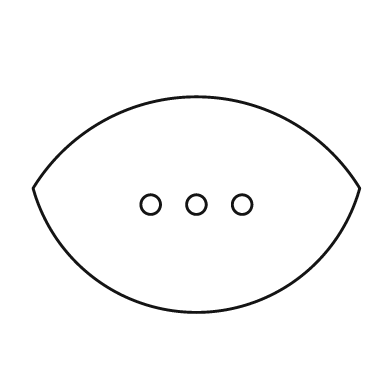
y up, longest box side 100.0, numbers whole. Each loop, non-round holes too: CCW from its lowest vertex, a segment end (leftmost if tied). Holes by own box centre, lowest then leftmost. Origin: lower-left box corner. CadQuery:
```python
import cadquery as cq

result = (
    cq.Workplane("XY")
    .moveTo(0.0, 38.0)
    .threePointArc((50.0, 0.0), (100.0, 38.0))
    .threePointArc((50.0, 66.0), (0.0, 38.0))
    .close()
    .moveTo(36.0, 33.0)
    .circle(3.0)
    .moveTo(50.0, 33.0)
    .circle(3.0)
    .moveTo(64.0, 33.0)
    .circle(3.0)
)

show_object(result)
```